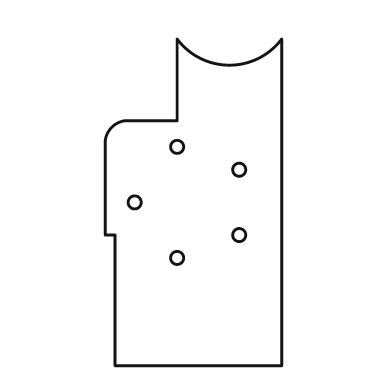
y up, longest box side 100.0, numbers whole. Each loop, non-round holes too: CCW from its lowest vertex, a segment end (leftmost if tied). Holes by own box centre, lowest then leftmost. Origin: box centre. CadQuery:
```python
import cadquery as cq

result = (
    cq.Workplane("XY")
    .moveTo(-24.0, -50.0)
    .lineTo(27.0, -50.0)
    .lineTo(27.0, 50.0)
    .threePointArc((11.0, 42.0), (-5.0, 50.0))
    .lineTo(-5.0, 25.0)
    .lineTo(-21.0, 25.0)
    .threePointArc((-25.0, 23.0), (-27.0, 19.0))
    .lineTo(-27.0, -10.0)
    .lineTo(-24.0, -10.0)
    .close()
    .moveTo(-5.0, -17.0)
    .circle(2.0)
    .moveTo(14.0, -10.0)
    .circle(2.0)
    .moveTo(-18.0, 0.0)
    .circle(2.0)
    .moveTo(14.0, 10.0)
    .circle(2.0)
    .moveTo(-5.0, 17.0)
    .circle(2.0)
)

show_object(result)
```